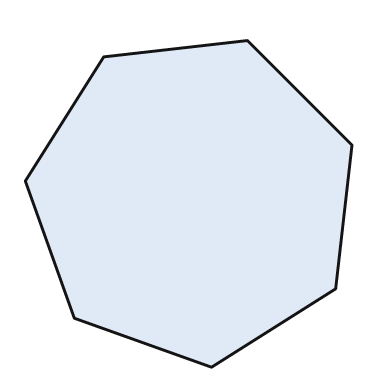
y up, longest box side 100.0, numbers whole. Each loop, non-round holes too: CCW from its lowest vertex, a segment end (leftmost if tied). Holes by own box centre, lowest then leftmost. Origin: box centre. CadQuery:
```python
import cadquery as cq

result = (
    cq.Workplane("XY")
    .moveTo(7.0, -50.0)
    .lineTo(45.0, -26.0)
    .lineTo(50.0, 18.0)
    .lineTo(18.0, 50.0)
    .lineTo(-26.0, 45.0)
    .lineTo(-50.0, 7.0)
    .lineTo(-35.0, -35.0)
    .close()
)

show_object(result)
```